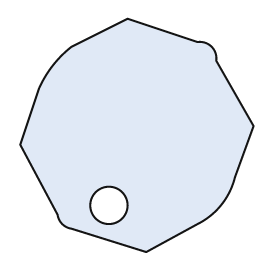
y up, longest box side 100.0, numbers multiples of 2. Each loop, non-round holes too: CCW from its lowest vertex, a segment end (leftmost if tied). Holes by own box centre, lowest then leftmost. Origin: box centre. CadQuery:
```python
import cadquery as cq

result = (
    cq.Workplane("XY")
    .moveTo(4.0, -50.0)
    .lineTo(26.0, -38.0)
    .threePointArc((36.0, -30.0), (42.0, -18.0))
    .lineTo(50.0, 4.0)
    .lineTo(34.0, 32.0)
    .threePointArc((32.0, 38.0), (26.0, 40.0))
    .lineTo(-4.0, 50.0)
    .lineTo(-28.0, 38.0)
    .threePointArc((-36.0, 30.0), (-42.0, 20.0))
    .lineTo(-50.0, -4.0)
    .lineTo(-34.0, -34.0)
    .threePointArc((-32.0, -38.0), (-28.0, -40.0))
    .close()
    .moveTo(-12.0, -30.0)
    .circle(8.0)
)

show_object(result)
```